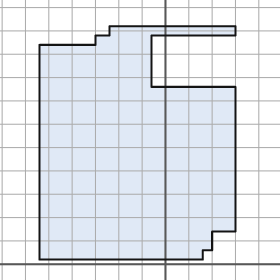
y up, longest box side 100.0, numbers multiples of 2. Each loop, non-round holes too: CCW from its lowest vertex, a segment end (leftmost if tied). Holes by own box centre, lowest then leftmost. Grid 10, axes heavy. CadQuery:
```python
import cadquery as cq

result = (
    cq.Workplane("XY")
    .moveTo(-54.0, 2.0)
    .lineTo(16.0, 2.0)
    .lineTo(16.0, 6.0)
    .lineTo(20.0, 6.0)
    .lineTo(20.0, 14.0)
    .lineTo(30.0, 14.0)
    .lineTo(30.0, 76.0)
    .lineTo(-6.0, 76.0)
    .lineTo(-6.0, 98.0)
    .lineTo(30.0, 98.0)
    .lineTo(30.0, 102.0)
    .lineTo(-24.0, 102.0)
    .lineTo(-24.0, 98.0)
    .lineTo(-30.0, 98.0)
    .lineTo(-30.0, 94.0)
    .lineTo(-54.0, 94.0)
    .close()
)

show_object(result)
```